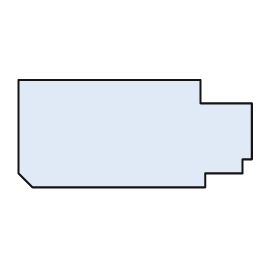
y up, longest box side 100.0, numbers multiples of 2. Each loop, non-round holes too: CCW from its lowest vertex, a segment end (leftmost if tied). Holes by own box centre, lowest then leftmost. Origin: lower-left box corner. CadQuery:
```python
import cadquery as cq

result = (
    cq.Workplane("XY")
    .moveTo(6.0, 0.0)
    .lineTo(80.0, 0.0)
    .lineTo(80.0, 6.0)
    .lineTo(96.0, 6.0)
    .lineTo(96.0, 12.0)
    .lineTo(100.0, 12.0)
    .lineTo(100.0, 36.0)
    .lineTo(78.0, 36.0)
    .lineTo(78.0, 46.0)
    .lineTo(0.0, 46.0)
    .lineTo(0.0, 6.0)
    .close()
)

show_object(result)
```